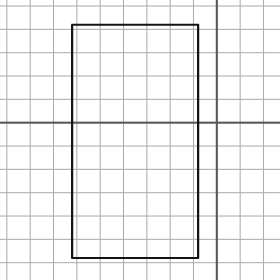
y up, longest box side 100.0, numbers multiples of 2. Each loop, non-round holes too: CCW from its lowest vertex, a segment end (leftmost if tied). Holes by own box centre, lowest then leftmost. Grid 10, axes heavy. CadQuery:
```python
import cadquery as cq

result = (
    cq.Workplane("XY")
    .moveTo(-62.0, -58.0)
    .lineTo(-8.0, -58.0)
    .lineTo(-8.0, 42.0)
    .lineTo(-62.0, 42.0)
    .close()
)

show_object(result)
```